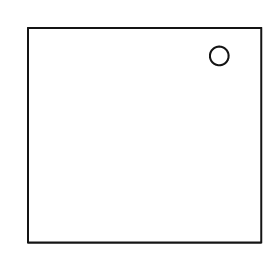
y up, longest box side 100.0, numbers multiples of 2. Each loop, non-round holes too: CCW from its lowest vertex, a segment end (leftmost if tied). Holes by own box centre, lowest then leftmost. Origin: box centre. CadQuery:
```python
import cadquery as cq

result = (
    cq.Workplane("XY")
    .moveTo(-50.0, -46.0)
    .lineTo(50.0, -46.0)
    .lineTo(50.0, 46.0)
    .lineTo(-50.0, 46.0)
    .close()
    .moveTo(32.0, 34.0)
    .circle(4.0)
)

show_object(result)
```